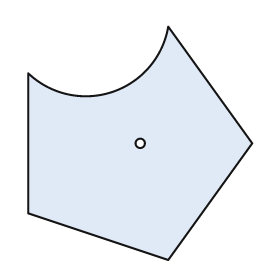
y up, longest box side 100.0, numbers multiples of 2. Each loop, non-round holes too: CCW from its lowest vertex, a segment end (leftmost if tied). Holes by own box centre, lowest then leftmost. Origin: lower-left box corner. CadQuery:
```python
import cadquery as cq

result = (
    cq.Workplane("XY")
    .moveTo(60.0, 0.0)
    .lineTo(96.0, 50.0)
    .lineTo(60.0, 100.0)
    .threePointArc((36.0, 72.0), (0.0, 80.0))
    .lineTo(0.0, 20.0)
    .close()
    .moveTo(48.0, 50.0)
    .circle(2.0)
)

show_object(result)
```